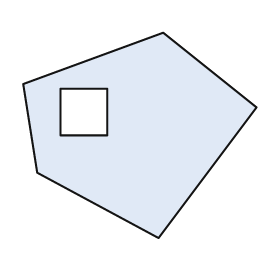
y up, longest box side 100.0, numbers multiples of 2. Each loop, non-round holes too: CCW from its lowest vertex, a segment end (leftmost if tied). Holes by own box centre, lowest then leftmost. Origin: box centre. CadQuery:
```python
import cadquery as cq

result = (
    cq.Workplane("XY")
    .moveTo(8.0, -44.0)
    .lineTo(50.0, 12.0)
    .lineTo(10.0, 44.0)
    .lineTo(-50.0, 22.0)
    .lineTo(-44.0, -16.0)
    .close()
    .moveTo(-34.0, 0.0)
    .lineTo(-14.0, 0.0)
    .lineTo(-14.0, 20.0)
    .lineTo(-34.0, 20.0)
    .close()
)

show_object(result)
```